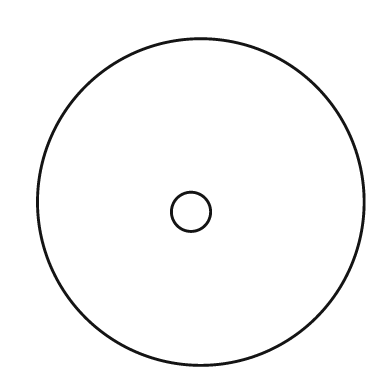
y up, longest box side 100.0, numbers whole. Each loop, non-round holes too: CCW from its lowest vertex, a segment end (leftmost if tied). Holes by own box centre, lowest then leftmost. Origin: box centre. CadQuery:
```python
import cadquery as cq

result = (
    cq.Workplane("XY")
    .moveTo(0.0, 0.0)
    .circle(50.0)
    .moveTo(-3.0, -3.0)
    .circle(6.0)
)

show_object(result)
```